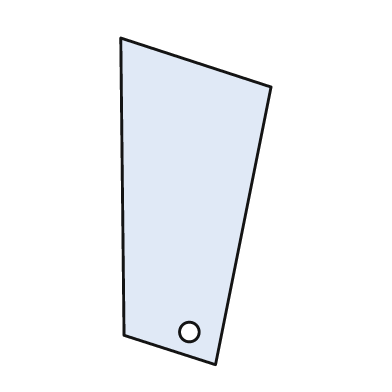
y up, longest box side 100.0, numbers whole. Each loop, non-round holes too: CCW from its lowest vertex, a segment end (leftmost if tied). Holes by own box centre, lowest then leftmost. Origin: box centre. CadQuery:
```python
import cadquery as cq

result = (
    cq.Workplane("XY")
    .moveTo(6.0, -50.0)
    .lineTo(23.0, 35.0)
    .lineTo(-23.0, 50.0)
    .lineTo(-22.0, -41.0)
    .close()
    .moveTo(-2.0, -40.0)
    .circle(3.0)
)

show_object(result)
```